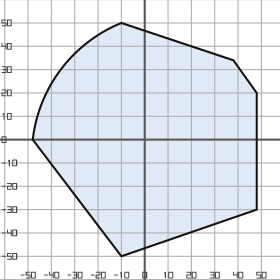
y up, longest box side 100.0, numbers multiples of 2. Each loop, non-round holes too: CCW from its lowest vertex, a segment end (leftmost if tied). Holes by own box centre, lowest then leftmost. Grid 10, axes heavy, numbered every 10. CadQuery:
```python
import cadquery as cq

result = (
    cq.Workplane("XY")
    .moveTo(-10.0, -50.0)
    .lineTo(48.0, -30.0)
    .lineTo(48.0, 20.0)
    .lineTo(38.0, 34.0)
    .lineTo(-10.0, 50.0)
    .threePointArc((-36.0, 30.0), (-48.0, 0.0))
    .close()
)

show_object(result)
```